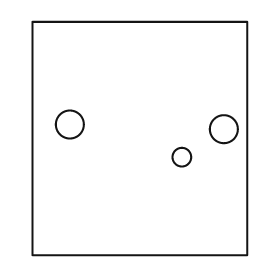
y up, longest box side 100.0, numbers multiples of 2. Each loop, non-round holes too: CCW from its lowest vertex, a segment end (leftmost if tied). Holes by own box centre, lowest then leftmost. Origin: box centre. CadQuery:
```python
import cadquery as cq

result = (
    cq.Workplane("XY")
    .moveTo(-46.0, -50.0)
    .lineTo(46.0, -50.0)
    .lineTo(46.0, 50.0)
    .lineTo(-46.0, 50.0)
    .close()
    .moveTo(18.0, -8.0)
    .circle(4.0)
    .moveTo(36.0, 4.0)
    .circle(6.0)
    .moveTo(-30.0, 6.0)
    .circle(6.0)
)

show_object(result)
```